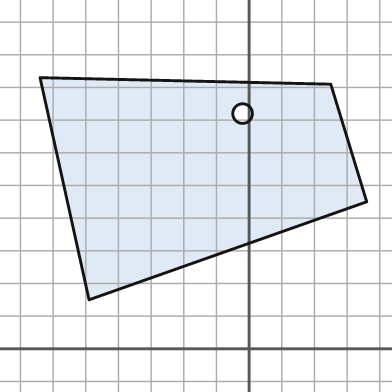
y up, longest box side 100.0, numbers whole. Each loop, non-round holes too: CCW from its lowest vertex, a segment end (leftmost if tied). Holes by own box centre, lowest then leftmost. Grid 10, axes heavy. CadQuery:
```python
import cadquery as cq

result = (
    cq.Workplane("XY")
    .moveTo(-49.0, 15.0)
    .lineTo(36.0, 45.0)
    .lineTo(25.0, 81.0)
    .lineTo(-64.0, 83.0)
    .close()
    .moveTo(-2.0, 72.0)
    .circle(3.0)
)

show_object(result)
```